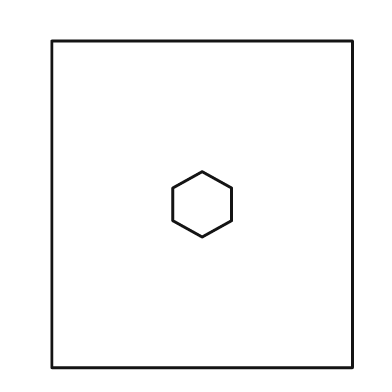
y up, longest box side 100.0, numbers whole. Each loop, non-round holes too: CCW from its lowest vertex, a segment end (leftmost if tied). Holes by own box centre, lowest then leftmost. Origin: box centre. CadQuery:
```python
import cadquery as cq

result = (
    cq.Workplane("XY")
    .moveTo(-46.0, -50.0)
    .lineTo(46.0, -50.0)
    .lineTo(46.0, 50.0)
    .lineTo(-46.0, 50.0)
    .close()
    .moveTo(0.0, -10.0)
    .lineTo(9.0, -5.0)
    .lineTo(9.0, 5.0)
    .lineTo(0.0, 10.0)
    .lineTo(-9.0, 5.0)
    .lineTo(-9.0, -5.0)
    .close()
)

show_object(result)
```